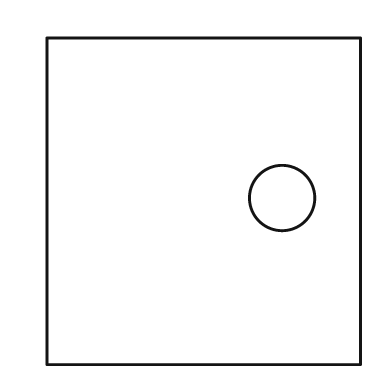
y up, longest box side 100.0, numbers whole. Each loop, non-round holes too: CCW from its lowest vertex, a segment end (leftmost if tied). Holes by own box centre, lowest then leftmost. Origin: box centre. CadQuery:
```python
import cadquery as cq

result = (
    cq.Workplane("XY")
    .moveTo(-48.0, -50.0)
    .lineTo(48.0, -50.0)
    .lineTo(48.0, 50.0)
    .lineTo(-48.0, 50.0)
    .close()
    .moveTo(24.0, 1.0)
    .circle(10.0)
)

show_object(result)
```